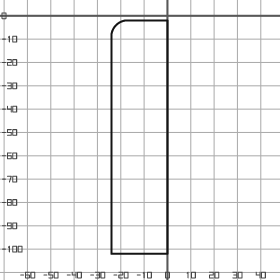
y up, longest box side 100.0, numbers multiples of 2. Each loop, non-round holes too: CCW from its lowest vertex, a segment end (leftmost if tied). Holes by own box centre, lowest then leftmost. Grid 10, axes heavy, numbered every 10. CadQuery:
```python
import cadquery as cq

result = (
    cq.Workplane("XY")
    .moveTo(-24.0, -102.0)
    .lineTo(0.0, -102.0)
    .lineTo(0.0, -2.0)
    .lineTo(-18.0, -2.0)
    .threePointArc((-22.0, -4.0), (-24.0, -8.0))
    .close()
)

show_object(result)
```